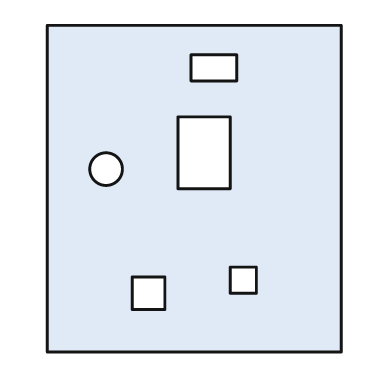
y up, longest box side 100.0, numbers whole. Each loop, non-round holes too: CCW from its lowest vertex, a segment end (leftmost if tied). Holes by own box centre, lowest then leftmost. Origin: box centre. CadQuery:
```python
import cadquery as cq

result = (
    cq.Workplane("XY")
    .moveTo(-45.0, -50.0)
    .lineTo(45.0, -50.0)
    .lineTo(45.0, 50.0)
    .lineTo(-45.0, 50.0)
    .close()
    .moveTo(-19.0, -37.0)
    .lineTo(-9.0, -37.0)
    .lineTo(-9.0, -27.0)
    .lineTo(-19.0, -27.0)
    .close()
    .moveTo(11.0, -32.0)
    .lineTo(19.0, -32.0)
    .lineTo(19.0, -24.0)
    .lineTo(11.0, -24.0)
    .close()
    .moveTo(-27.0, 6.0)
    .circle(5.0)
    .moveTo(-5.0, 0.0)
    .lineTo(11.0, 0.0)
    .lineTo(11.0, 22.0)
    .lineTo(-5.0, 22.0)
    .close()
    .moveTo(-1.0, 33.0)
    .lineTo(13.0, 33.0)
    .lineTo(13.0, 41.0)
    .lineTo(-1.0, 41.0)
    .close()
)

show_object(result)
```